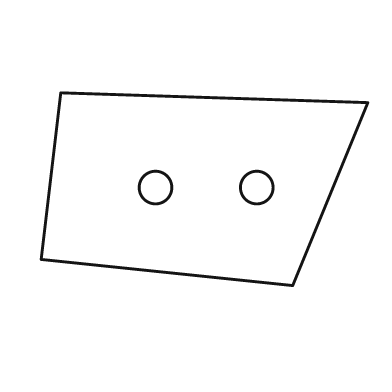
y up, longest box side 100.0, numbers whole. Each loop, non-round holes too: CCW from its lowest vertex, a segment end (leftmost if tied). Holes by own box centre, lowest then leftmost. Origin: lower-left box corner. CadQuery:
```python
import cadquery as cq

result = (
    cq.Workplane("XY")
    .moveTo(77.0, 0.0)
    .lineTo(100.0, 56.0)
    .lineTo(6.0, 59.0)
    .lineTo(0.0, 8.0)
    .close()
    .moveTo(35.0, 30.0)
    .circle(5.0)
    .moveTo(66.0, 30.0)
    .circle(5.0)
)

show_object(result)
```